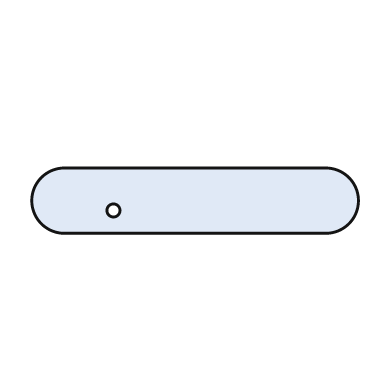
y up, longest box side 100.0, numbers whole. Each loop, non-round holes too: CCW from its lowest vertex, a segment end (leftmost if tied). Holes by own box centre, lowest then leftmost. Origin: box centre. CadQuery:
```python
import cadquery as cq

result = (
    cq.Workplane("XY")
    .moveTo(-40.0, -10.0)
    .lineTo(40.0, -10.0)
    .threePointArc((50.0, 0.0), (40.0, 10.0))
    .lineTo(-40.0, 10.0)
    .threePointArc((-50.0, 0.0), (-40.0, -10.0))
    .close()
    .moveTo(-25.0, -3.0)
    .circle(2.0)
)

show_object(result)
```